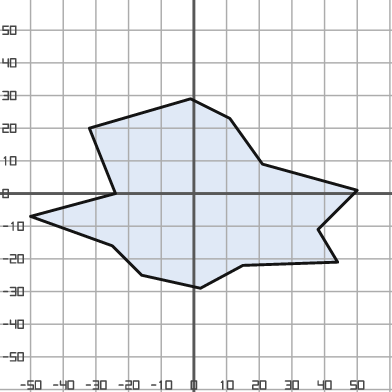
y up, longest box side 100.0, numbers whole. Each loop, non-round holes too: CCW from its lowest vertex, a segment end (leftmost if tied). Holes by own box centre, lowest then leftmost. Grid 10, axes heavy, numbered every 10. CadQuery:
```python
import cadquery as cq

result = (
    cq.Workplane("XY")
    .moveTo(2.0, -29.0)
    .lineTo(15.0, -22.0)
    .lineTo(44.0, -21.0)
    .lineTo(38.0, -11.0)
    .lineTo(50.0, 1.0)
    .lineTo(21.0, 9.0)
    .lineTo(11.0, 23.0)
    .lineTo(-1.0, 29.0)
    .lineTo(-32.0, 20.0)
    .lineTo(-24.0, 0.0)
    .lineTo(-50.0, -7.0)
    .lineTo(-25.0, -16.0)
    .lineTo(-16.0, -25.0)
    .close()
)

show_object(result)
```